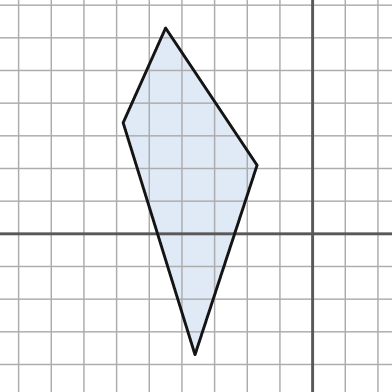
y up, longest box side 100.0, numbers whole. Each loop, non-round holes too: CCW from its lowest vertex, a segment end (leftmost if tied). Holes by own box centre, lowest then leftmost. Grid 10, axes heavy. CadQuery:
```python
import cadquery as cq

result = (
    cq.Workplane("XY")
    .moveTo(-36.0, -37.0)
    .lineTo(-17.0, 21.0)
    .lineTo(-45.0, 63.0)
    .lineTo(-58.0, 34.0)
    .close()
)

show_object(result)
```